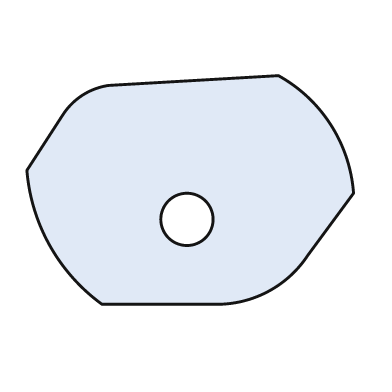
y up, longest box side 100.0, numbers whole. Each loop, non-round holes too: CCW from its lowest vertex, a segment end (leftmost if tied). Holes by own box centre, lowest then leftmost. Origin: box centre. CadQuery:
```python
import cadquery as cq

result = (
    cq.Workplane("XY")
    .moveTo(-27.0, -35.0)
    .lineTo(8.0, -35.0)
    .threePointArc((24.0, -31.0), (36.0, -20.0))
    .lineTo(50.0, -1.0)
    .threePointArc((43.0, 20.0), (27.0, 35.0))
    .lineTo(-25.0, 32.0)
    .threePointArc((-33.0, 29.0), (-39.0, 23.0))
    .lineTo(-50.0, 6.0)
    .threePointArc((-43.0, -17.0), (-27.0, -35.0))
    .close()
    .moveTo(-1.0, -9.0)
    .circle(8.0)
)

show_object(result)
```